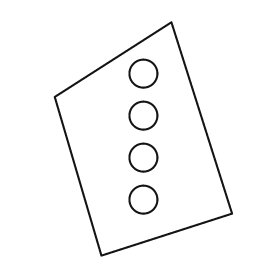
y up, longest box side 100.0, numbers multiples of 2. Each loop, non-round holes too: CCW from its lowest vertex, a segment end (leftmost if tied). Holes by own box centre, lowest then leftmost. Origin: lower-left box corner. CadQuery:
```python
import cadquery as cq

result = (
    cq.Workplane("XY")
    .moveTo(20.0, 0.0)
    .lineTo(76.0, 18.0)
    .lineTo(50.0, 100.0)
    .lineTo(0.0, 68.0)
    .close()
    .moveTo(38.0, 24.0)
    .circle(6.0)
    .moveTo(38.0, 42.0)
    .circle(6.0)
    .moveTo(38.0, 60.0)
    .circle(6.0)
    .moveTo(38.0, 78.0)
    .circle(6.0)
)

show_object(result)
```